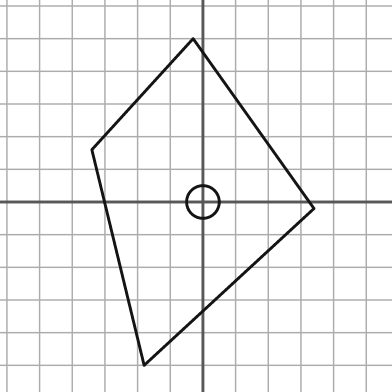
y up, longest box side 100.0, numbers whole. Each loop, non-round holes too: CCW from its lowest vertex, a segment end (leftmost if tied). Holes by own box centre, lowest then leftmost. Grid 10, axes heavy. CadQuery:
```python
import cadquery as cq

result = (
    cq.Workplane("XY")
    .moveTo(-18.0, -50.0)
    .lineTo(34.0, -2.0)
    .lineTo(-3.0, 50.0)
    .lineTo(-34.0, 16.0)
    .close()
    .moveTo(0.0, 0.0)
    .circle(5.0)
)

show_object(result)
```